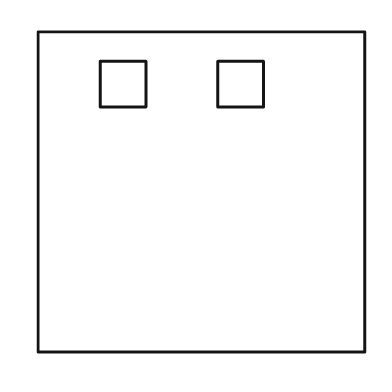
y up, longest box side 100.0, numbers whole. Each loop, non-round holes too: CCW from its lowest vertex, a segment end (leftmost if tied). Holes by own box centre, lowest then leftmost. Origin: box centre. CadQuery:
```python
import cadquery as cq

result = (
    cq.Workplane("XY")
    .moveTo(-50.0, -49.0)
    .lineTo(50.0, -49.0)
    .lineTo(50.0, 49.0)
    .lineTo(-50.0, 49.0)
    .close()
    .moveTo(-31.0, 26.0)
    .lineTo(-17.0, 26.0)
    .lineTo(-17.0, 40.0)
    .lineTo(-31.0, 40.0)
    .close()
    .moveTo(5.0, 26.0)
    .lineTo(19.0, 26.0)
    .lineTo(19.0, 40.0)
    .lineTo(5.0, 40.0)
    .close()
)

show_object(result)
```